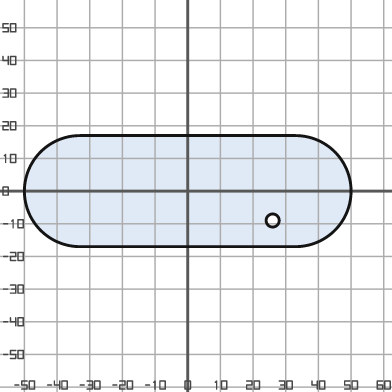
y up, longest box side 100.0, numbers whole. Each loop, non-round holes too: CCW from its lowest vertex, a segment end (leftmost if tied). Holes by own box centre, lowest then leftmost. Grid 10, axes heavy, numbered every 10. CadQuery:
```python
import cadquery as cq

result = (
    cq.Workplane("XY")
    .moveTo(-33.0, -17.0)
    .lineTo(33.0, -17.0)
    .threePointArc((50.0, 0.0), (33.0, 17.0))
    .lineTo(-33.0, 17.0)
    .threePointArc((-50.0, 0.0), (-33.0, -17.0))
    .close()
    .moveTo(26.0, -9.0)
    .circle(2.0)
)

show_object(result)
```